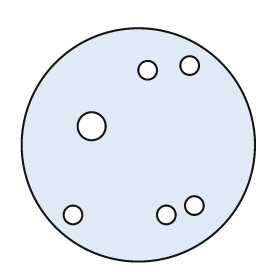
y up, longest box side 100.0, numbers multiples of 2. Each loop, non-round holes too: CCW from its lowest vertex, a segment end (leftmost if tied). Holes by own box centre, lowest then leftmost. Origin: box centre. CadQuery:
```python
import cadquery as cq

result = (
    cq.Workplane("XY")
    .moveTo(0.0, 0.0)
    .circle(50.0)
    .moveTo(-28.0, -30.0)
    .circle(4.0)
    .moveTo(12.0, -30.0)
    .circle(4.0)
    .moveTo(24.0, -26.0)
    .circle(4.0)
    .moveTo(-20.0, 8.0)
    .circle(6.0)
    .moveTo(4.0, 32.0)
    .circle(4.0)
    .moveTo(22.0, 34.0)
    .circle(4.0)
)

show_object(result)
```